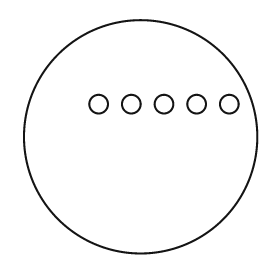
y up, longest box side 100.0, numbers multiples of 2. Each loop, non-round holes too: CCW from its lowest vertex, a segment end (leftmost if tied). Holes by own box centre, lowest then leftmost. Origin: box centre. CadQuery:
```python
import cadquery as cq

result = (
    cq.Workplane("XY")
    .moveTo(0.0, 0.0)
    .circle(50.0)
    .moveTo(-18.0, 14.0)
    .circle(4.0)
    .moveTo(-4.0, 14.0)
    .circle(4.0)
    .moveTo(10.0, 14.0)
    .circle(4.0)
    .moveTo(24.0, 14.0)
    .circle(4.0)
    .moveTo(38.0, 14.0)
    .circle(4.0)
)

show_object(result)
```